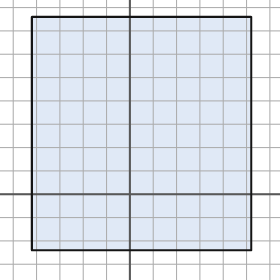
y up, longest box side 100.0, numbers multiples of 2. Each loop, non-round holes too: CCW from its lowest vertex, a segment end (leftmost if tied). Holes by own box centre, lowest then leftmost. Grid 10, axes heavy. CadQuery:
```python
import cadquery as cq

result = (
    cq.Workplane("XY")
    .moveTo(-42.0, -24.0)
    .lineTo(52.0, -24.0)
    .lineTo(52.0, 76.0)
    .lineTo(-42.0, 76.0)
    .close()
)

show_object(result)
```